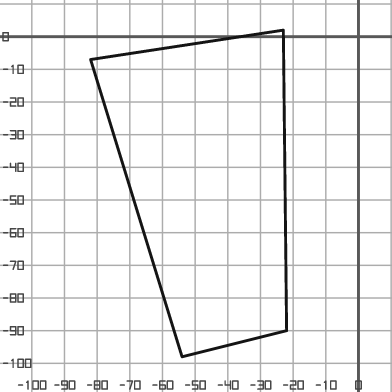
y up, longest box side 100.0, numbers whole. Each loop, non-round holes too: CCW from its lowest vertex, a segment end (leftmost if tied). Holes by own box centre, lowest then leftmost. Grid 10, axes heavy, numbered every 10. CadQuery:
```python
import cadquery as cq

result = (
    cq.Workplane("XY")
    .moveTo(-54.0, -98.0)
    .lineTo(-22.0, -90.0)
    .lineTo(-23.0, 2.0)
    .lineTo(-82.0, -7.0)
    .close()
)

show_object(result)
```